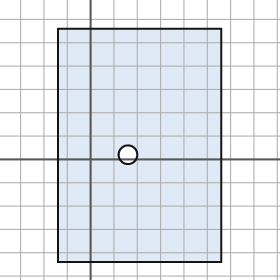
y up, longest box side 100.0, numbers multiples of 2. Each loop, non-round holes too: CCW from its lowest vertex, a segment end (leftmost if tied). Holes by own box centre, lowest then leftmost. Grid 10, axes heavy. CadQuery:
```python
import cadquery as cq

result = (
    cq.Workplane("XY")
    .moveTo(-14.0, -44.0)
    .lineTo(56.0, -44.0)
    .lineTo(56.0, 56.0)
    .lineTo(-14.0, 56.0)
    .close()
    .moveTo(16.0, 2.0)
    .circle(4.0)
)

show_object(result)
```